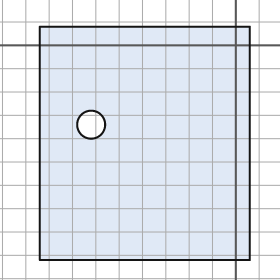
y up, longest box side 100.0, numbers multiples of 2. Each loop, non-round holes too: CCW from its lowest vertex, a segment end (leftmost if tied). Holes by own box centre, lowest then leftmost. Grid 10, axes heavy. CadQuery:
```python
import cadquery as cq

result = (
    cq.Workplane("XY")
    .moveTo(-84.0, -92.0)
    .lineTo(6.0, -92.0)
    .lineTo(6.0, 8.0)
    .lineTo(-84.0, 8.0)
    .close()
    .moveTo(-62.0, -34.0)
    .circle(6.0)
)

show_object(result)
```